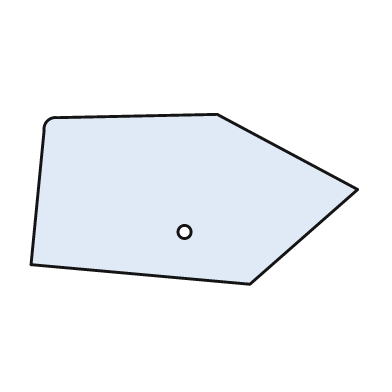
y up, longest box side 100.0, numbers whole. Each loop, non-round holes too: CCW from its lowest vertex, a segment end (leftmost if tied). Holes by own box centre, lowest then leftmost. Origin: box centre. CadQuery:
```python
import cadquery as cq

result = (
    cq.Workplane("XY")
    .moveTo(17.0, -26.0)
    .lineTo(50.0, 3.0)
    .lineTo(7.0, 26.0)
    .lineTo(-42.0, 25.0)
    .threePointArc((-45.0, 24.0), (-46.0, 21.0))
    .lineTo(-50.0, -20.0)
    .close()
    .moveTo(-3.0, -10.0)
    .circle(2.0)
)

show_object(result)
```